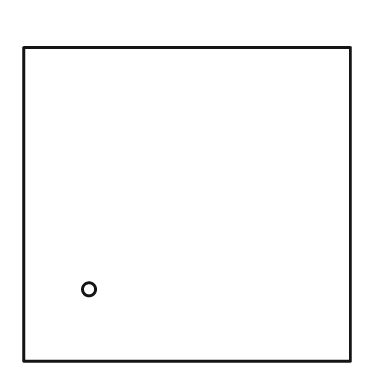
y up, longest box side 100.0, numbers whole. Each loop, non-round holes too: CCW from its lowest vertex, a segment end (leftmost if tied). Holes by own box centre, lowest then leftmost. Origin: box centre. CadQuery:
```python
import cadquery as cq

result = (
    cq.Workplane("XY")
    .moveTo(-50.0, -48.0)
    .lineTo(50.0, -48.0)
    .lineTo(50.0, 48.0)
    .lineTo(-50.0, 48.0)
    .close()
    .moveTo(-30.0, -26.0)
    .circle(2.0)
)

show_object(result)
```